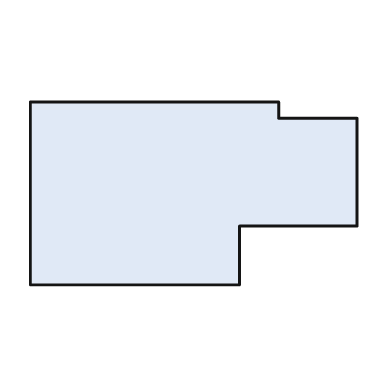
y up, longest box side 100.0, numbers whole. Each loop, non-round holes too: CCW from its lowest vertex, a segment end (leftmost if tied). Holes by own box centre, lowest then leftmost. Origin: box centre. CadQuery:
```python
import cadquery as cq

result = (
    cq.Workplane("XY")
    .moveTo(-50.0, -28.0)
    .lineTo(14.0, -28.0)
    .lineTo(14.0, -10.0)
    .lineTo(50.0, -10.0)
    .lineTo(50.0, 23.0)
    .lineTo(26.0, 23.0)
    .lineTo(26.0, 28.0)
    .lineTo(-50.0, 28.0)
    .close()
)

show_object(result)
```